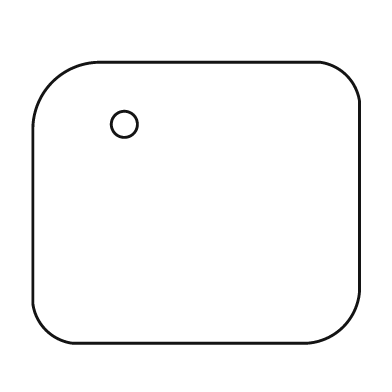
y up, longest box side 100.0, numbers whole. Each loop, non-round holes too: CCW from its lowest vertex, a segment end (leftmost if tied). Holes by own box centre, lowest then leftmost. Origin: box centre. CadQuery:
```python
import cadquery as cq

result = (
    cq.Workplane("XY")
    .moveTo(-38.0, -43.0)
    .lineTo(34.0, -43.0)
    .threePointArc((45.0, -38.0), (50.0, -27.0))
    .lineTo(50.0, 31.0)
    .threePointArc((46.0, 39.0), (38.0, 43.0))
    .lineTo(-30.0, 43.0)
    .threePointArc((-44.0, 37.0), (-50.0, 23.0))
    .lineTo(-50.0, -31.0)
    .threePointArc((-46.0, -39.0), (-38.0, -43.0))
    .close()
    .moveTo(-22.0, 24.0)
    .circle(4.0)
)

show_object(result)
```